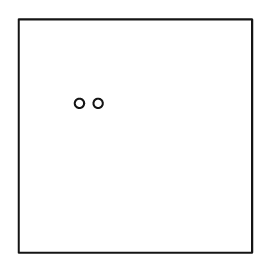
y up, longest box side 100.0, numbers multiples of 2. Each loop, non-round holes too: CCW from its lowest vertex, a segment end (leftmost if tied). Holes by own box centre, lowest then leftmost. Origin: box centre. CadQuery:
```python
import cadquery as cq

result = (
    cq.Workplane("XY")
    .moveTo(-50.0, -50.0)
    .lineTo(50.0, -50.0)
    .lineTo(50.0, 50.0)
    .lineTo(-50.0, 50.0)
    .close()
    .moveTo(-24.0, 14.0)
    .circle(2.0)
    .moveTo(-16.0, 14.0)
    .circle(2.0)
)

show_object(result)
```